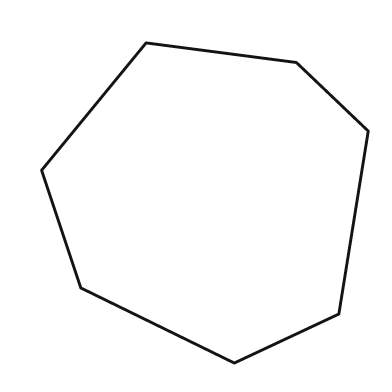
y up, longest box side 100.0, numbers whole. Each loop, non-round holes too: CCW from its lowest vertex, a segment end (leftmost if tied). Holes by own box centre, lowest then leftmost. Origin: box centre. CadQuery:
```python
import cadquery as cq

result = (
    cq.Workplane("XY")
    .moveTo(9.0, -49.0)
    .lineTo(41.0, -34.0)
    .lineTo(50.0, 22.0)
    .lineTo(28.0, 43.0)
    .lineTo(-18.0, 49.0)
    .lineTo(-50.0, 10.0)
    .lineTo(-38.0, -26.0)
    .close()
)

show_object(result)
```